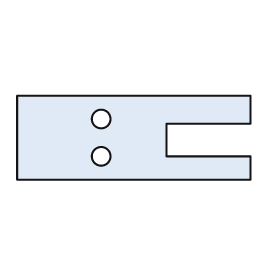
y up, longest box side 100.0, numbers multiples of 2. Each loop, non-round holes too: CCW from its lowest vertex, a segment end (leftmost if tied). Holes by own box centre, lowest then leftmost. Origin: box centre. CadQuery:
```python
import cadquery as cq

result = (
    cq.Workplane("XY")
    .moveTo(-50.0, -18.0)
    .lineTo(50.0, -18.0)
    .lineTo(50.0, -8.0)
    .lineTo(14.0, -8.0)
    .lineTo(14.0, 6.0)
    .lineTo(50.0, 6.0)
    .lineTo(50.0, 18.0)
    .lineTo(-50.0, 18.0)
    .close()
    .moveTo(-14.0, -8.0)
    .circle(4.0)
    .moveTo(-14.0, 8.0)
    .circle(4.0)
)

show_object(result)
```